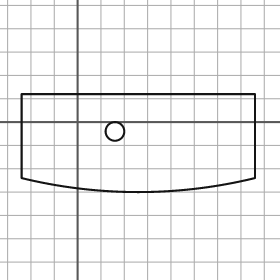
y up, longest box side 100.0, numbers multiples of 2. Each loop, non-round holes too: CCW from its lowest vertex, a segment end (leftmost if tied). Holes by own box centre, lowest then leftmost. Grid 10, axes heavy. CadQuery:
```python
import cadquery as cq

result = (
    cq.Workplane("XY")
    .moveTo(-24.0, -24.0)
    .threePointArc((26.0, -30.0), (76.0, -24.0))
    .lineTo(76.0, 12.0)
    .lineTo(-24.0, 12.0)
    .close()
    .moveTo(16.0, -4.0)
    .circle(4.0)
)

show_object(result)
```